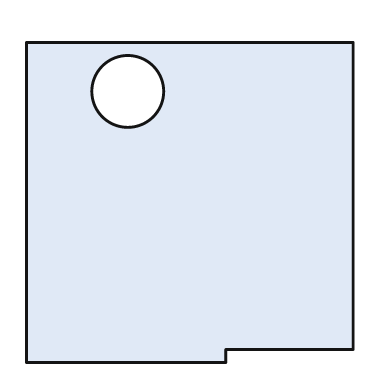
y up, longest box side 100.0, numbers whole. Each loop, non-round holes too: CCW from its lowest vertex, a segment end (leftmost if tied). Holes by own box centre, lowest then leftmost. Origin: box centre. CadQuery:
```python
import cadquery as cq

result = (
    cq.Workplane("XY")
    .moveTo(-50.0, -49.0)
    .lineTo(11.0, -49.0)
    .lineTo(11.0, -45.0)
    .lineTo(50.0, -45.0)
    .lineTo(50.0, 49.0)
    .lineTo(-50.0, 49.0)
    .close()
    .moveTo(-19.0, 34.0)
    .circle(11.0)
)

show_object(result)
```